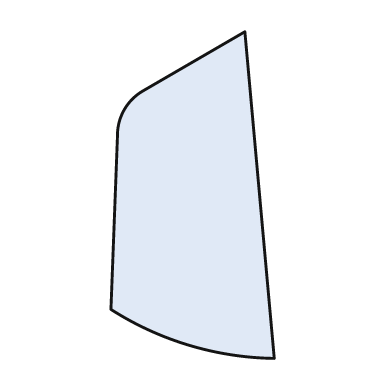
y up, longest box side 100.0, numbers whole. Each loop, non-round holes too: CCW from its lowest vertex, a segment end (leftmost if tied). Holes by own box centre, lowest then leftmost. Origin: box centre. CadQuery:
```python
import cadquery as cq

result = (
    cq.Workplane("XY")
    .moveTo(25.0, -50.0)
    .lineTo(16.0, 50.0)
    .lineTo(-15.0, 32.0)
    .threePointArc((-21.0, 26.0), (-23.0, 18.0))
    .lineTo(-25.0, -35.0)
    .threePointArc((-1.0, -46.0), (25.0, -50.0))
    .close()
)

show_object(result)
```